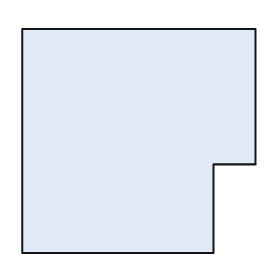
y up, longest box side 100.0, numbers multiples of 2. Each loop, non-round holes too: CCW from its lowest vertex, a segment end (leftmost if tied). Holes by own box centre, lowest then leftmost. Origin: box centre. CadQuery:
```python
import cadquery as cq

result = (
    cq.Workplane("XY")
    .moveTo(-50.0, -48.0)
    .lineTo(32.0, -48.0)
    .lineTo(32.0, -10.0)
    .lineTo(50.0, -10.0)
    .lineTo(50.0, 48.0)
    .lineTo(-50.0, 48.0)
    .close()
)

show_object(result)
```